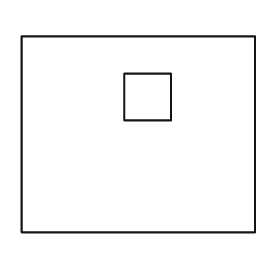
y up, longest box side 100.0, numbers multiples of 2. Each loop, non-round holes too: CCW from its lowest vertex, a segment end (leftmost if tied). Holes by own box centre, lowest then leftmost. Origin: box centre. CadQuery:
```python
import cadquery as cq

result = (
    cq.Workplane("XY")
    .moveTo(-50.0, -42.0)
    .lineTo(50.0, -42.0)
    .lineTo(50.0, 42.0)
    .lineTo(-50.0, 42.0)
    .close()
    .moveTo(-6.0, 6.0)
    .lineTo(14.0, 6.0)
    .lineTo(14.0, 26.0)
    .lineTo(-6.0, 26.0)
    .close()
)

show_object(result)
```